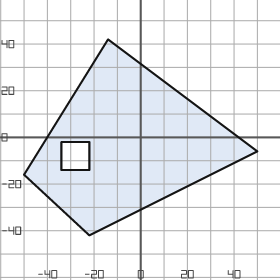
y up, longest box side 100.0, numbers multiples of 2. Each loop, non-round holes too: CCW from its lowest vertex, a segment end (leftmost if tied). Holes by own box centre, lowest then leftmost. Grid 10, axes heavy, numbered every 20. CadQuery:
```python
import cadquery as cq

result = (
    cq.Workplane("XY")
    .moveTo(-22.0, -42.0)
    .lineTo(50.0, -6.0)
    .lineTo(-14.0, 42.0)
    .lineTo(-50.0, -16.0)
    .close()
    .moveTo(-34.0, -14.0)
    .lineTo(-22.0, -14.0)
    .lineTo(-22.0, -2.0)
    .lineTo(-34.0, -2.0)
    .close()
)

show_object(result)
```